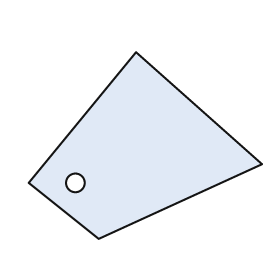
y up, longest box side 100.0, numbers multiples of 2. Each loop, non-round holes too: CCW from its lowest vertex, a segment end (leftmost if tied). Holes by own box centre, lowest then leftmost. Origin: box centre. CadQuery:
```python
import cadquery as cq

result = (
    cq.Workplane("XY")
    .moveTo(-20.0, -40.0)
    .lineTo(50.0, -8.0)
    .lineTo(-4.0, 40.0)
    .lineTo(-50.0, -16.0)
    .close()
    .moveTo(-30.0, -16.0)
    .circle(4.0)
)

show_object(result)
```